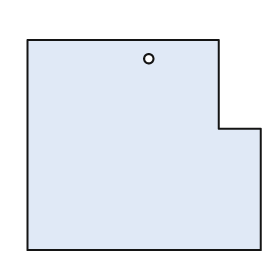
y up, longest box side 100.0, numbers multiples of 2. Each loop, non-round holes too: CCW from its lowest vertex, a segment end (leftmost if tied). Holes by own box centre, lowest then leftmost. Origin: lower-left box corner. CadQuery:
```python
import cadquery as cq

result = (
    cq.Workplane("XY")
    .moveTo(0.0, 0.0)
    .lineTo(100.0, 0.0)
    .lineTo(100.0, 52.0)
    .lineTo(82.0, 52.0)
    .lineTo(82.0, 90.0)
    .lineTo(0.0, 90.0)
    .close()
    .moveTo(52.0, 82.0)
    .circle(2.0)
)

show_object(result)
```